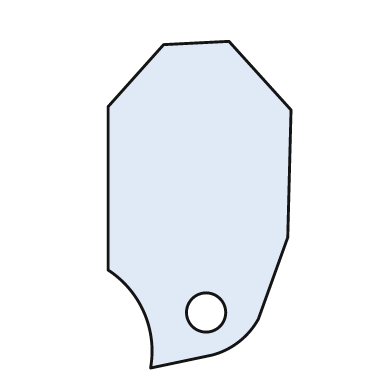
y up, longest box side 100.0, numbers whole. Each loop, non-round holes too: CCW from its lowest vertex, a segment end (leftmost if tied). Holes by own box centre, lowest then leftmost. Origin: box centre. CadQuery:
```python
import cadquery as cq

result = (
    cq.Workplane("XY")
    .moveTo(-15.0, -50.0)
    .lineTo(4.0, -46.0)
    .threePointArc((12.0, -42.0), (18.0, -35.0))
    .lineTo(27.0, -10.0)
    .lineTo(28.0, 29.0)
    .lineTo(9.0, 50.0)
    .lineTo(-11.0, 49.0)
    .lineTo(-28.0, 30.0)
    .lineTo(-28.0, -20.0)
    .threePointArc((-17.0, -33.0), (-15.0, -50.0))
    .close()
    .moveTo(2.0, -33.0)
    .circle(6.0)
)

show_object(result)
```